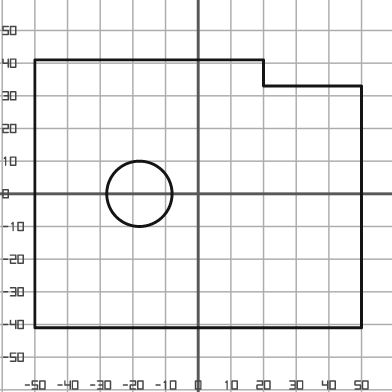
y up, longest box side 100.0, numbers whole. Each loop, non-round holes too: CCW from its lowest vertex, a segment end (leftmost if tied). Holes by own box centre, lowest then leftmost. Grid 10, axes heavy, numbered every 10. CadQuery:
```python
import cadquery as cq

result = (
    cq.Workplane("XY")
    .moveTo(-50.0, -41.0)
    .lineTo(50.0, -41.0)
    .lineTo(50.0, 33.0)
    .lineTo(20.0, 33.0)
    .lineTo(20.0, 41.0)
    .lineTo(-50.0, 41.0)
    .close()
    .moveTo(-18.0, 0.0)
    .circle(10.0)
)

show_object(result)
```